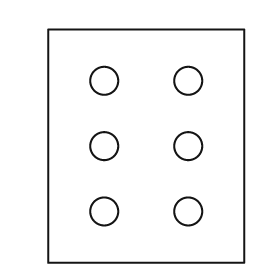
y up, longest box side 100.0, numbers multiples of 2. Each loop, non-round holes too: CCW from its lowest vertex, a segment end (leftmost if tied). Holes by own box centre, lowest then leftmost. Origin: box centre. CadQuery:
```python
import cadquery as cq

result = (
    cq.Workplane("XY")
    .moveTo(-42.0, -50.0)
    .lineTo(42.0, -50.0)
    .lineTo(42.0, 50.0)
    .lineTo(-42.0, 50.0)
    .close()
    .moveTo(-18.0, -28.0)
    .circle(6.0)
    .moveTo(18.0, -28.0)
    .circle(6.0)
    .moveTo(-18.0, 0.0)
    .circle(6.0)
    .moveTo(18.0, 0.0)
    .circle(6.0)
    .moveTo(-18.0, 28.0)
    .circle(6.0)
    .moveTo(18.0, 28.0)
    .circle(6.0)
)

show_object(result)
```